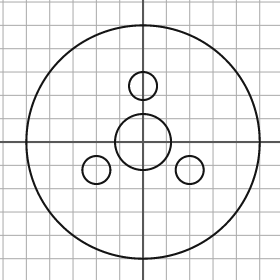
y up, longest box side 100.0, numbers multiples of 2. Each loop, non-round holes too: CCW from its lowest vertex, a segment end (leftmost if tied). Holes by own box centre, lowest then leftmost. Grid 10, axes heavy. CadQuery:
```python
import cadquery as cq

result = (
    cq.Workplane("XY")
    .moveTo(0.0, 0.0)
    .circle(50.0)
    .moveTo(-20.0, -12.0)
    .circle(6.0)
    .moveTo(20.0, -12.0)
    .circle(6.0)
    .moveTo(0.0, 0.0)
    .circle(12.0)
    .moveTo(0.0, 24.0)
    .circle(6.0)
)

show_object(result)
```